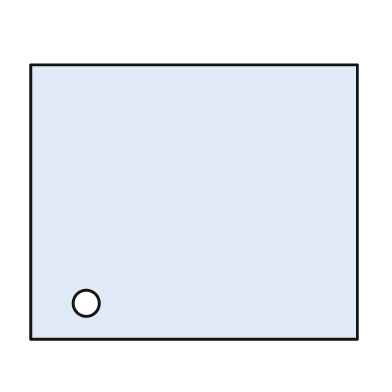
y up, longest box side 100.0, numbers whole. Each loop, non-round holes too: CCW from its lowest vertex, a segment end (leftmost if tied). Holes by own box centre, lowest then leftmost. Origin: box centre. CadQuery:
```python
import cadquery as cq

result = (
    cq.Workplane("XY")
    .moveTo(-50.0, -42.0)
    .lineTo(50.0, -42.0)
    .lineTo(50.0, 42.0)
    .lineTo(-50.0, 42.0)
    .close()
    .moveTo(-33.0, -31.0)
    .circle(4.0)
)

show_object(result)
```